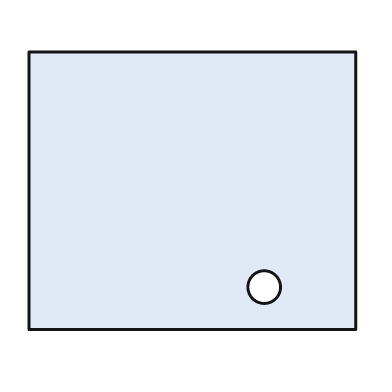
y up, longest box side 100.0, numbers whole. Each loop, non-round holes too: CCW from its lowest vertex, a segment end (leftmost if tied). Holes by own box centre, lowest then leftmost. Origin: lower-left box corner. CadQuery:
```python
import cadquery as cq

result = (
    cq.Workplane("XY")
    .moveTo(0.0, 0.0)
    .lineTo(100.0, 0.0)
    .lineTo(100.0, 85.0)
    .lineTo(0.0, 85.0)
    .close()
    .moveTo(72.0, 13.0)
    .circle(5.0)
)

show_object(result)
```